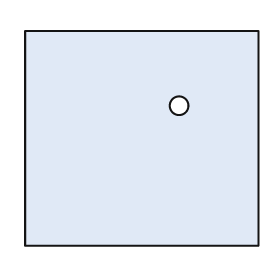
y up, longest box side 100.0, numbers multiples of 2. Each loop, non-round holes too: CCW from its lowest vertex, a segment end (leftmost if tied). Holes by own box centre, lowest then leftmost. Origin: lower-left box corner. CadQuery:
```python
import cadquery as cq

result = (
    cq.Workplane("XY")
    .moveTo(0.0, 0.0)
    .lineTo(100.0, 0.0)
    .lineTo(100.0, 92.0)
    .lineTo(0.0, 92.0)
    .close()
    .moveTo(66.0, 60.0)
    .circle(4.0)
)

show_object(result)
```